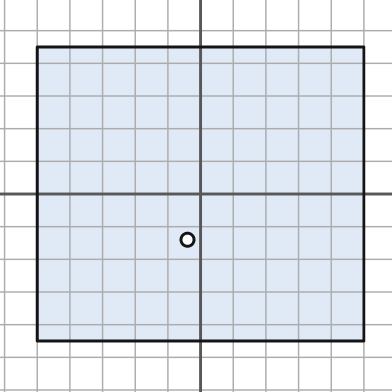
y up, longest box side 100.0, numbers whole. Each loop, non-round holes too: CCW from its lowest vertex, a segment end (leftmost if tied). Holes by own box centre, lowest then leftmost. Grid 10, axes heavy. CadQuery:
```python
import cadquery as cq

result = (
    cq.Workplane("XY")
    .moveTo(-50.0, -45.0)
    .lineTo(50.0, -45.0)
    .lineTo(50.0, 45.0)
    .lineTo(-50.0, 45.0)
    .close()
    .moveTo(-4.0, -14.0)
    .circle(2.0)
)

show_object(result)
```